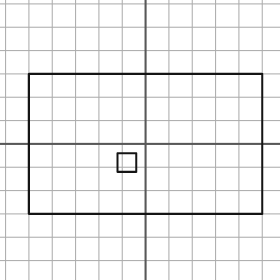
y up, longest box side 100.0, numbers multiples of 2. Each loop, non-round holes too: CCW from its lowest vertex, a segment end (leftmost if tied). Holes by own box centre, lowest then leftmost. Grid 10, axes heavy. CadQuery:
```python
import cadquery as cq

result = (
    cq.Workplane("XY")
    .moveTo(-50.0, -30.0)
    .lineTo(50.0, -30.0)
    .lineTo(50.0, 30.0)
    .lineTo(-50.0, 30.0)
    .close()
    .moveTo(-12.0, -12.0)
    .lineTo(-4.0, -12.0)
    .lineTo(-4.0, -4.0)
    .lineTo(-12.0, -4.0)
    .close()
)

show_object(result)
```